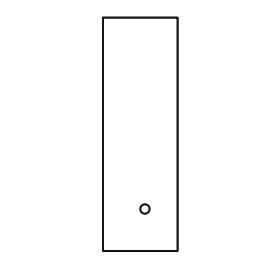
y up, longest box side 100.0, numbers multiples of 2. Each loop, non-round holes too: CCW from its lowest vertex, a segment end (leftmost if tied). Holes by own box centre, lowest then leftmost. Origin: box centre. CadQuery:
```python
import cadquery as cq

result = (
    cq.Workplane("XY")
    .moveTo(-16.0, -50.0)
    .lineTo(16.0, -50.0)
    .lineTo(16.0, 50.0)
    .lineTo(-16.0, 50.0)
    .close()
    .moveTo(2.0, -32.0)
    .circle(2.0)
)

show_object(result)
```